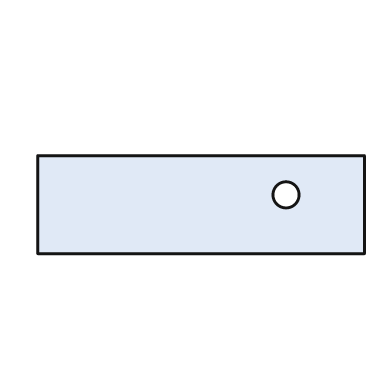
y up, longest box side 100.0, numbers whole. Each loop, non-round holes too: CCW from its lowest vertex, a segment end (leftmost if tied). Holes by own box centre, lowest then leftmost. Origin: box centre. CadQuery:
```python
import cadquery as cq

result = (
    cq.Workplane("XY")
    .moveTo(-50.0, -15.0)
    .lineTo(50.0, -15.0)
    .lineTo(50.0, 15.0)
    .lineTo(-50.0, 15.0)
    .close()
    .moveTo(26.0, 3.0)
    .circle(4.0)
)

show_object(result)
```